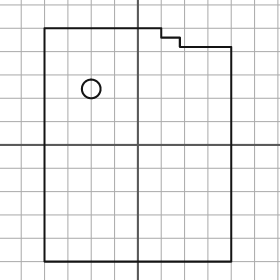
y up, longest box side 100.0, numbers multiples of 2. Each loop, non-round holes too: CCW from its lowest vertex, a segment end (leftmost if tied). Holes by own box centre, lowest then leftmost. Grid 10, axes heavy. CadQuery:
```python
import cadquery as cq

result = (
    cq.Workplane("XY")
    .moveTo(-40.0, -50.0)
    .lineTo(40.0, -50.0)
    .lineTo(40.0, 42.0)
    .lineTo(18.0, 42.0)
    .lineTo(18.0, 46.0)
    .lineTo(10.0, 46.0)
    .lineTo(10.0, 50.0)
    .lineTo(-40.0, 50.0)
    .close()
    .moveTo(-20.0, 24.0)
    .circle(4.0)
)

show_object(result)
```